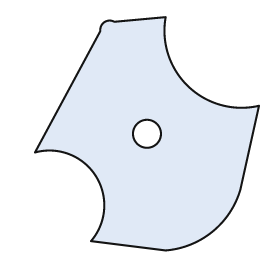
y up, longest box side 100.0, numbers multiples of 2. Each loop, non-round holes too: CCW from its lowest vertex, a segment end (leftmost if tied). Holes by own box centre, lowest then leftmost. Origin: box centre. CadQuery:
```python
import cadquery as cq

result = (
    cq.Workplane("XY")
    .moveTo(8.0, -50.0)
    .threePointArc((28.0, -42.0), (40.0, -24.0))
    .lineTo(48.0, 12.0)
    .threePointArc((18.0, 20.0), (8.0, 50.0))
    .lineTo(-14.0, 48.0)
    .threePointArc((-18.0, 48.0), (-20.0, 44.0))
    .lineTo(-48.0, -8.0)
    .threePointArc((-22.0, -18.0), (-24.0, -46.0))
    .close()
    .moveTo(0.0, 0.0)
    .circle(6.0)
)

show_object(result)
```